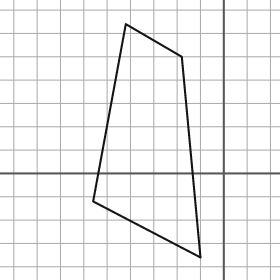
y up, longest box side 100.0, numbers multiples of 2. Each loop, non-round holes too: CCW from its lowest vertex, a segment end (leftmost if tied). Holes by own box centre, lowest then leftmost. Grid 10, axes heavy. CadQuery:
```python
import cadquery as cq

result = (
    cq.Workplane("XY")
    .moveTo(-10.0, -36.0)
    .lineTo(-18.0, 50.0)
    .lineTo(-42.0, 64.0)
    .lineTo(-56.0, -12.0)
    .close()
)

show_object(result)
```